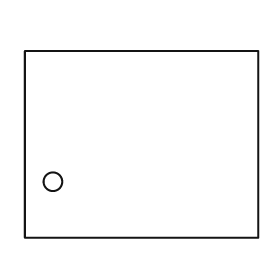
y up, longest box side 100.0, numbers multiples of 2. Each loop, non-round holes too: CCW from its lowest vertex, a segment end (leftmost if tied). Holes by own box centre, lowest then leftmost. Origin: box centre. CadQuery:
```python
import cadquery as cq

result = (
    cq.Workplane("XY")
    .moveTo(-50.0, -40.0)
    .lineTo(50.0, -40.0)
    .lineTo(50.0, 40.0)
    .lineTo(-50.0, 40.0)
    .close()
    .moveTo(-38.0, -16.0)
    .circle(4.0)
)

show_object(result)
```